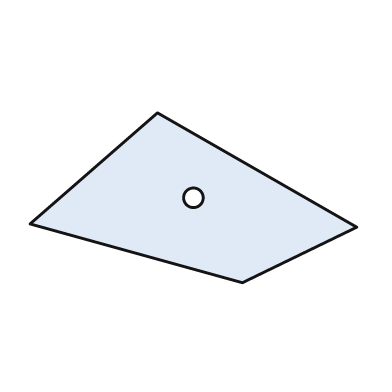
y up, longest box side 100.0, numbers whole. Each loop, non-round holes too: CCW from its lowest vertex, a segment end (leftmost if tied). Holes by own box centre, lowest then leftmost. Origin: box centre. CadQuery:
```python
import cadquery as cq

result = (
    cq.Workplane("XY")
    .moveTo(15.0, -26.0)
    .lineTo(50.0, -9.0)
    .lineTo(-11.0, 26.0)
    .lineTo(-50.0, -8.0)
    .close()
    .moveTo(0.0, 0.0)
    .circle(3.0)
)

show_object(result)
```